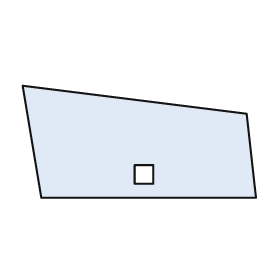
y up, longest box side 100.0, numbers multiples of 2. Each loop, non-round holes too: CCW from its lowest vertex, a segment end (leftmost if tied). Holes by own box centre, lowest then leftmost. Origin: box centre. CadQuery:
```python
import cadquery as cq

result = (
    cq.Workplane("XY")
    .moveTo(-42.0, -24.0)
    .lineTo(50.0, -24.0)
    .lineTo(46.0, 12.0)
    .lineTo(-50.0, 24.0)
    .close()
    .moveTo(-2.0, -18.0)
    .lineTo(6.0, -18.0)
    .lineTo(6.0, -10.0)
    .lineTo(-2.0, -10.0)
    .close()
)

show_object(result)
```